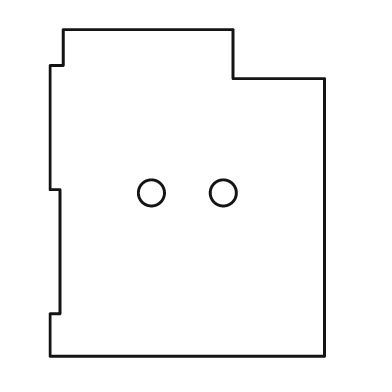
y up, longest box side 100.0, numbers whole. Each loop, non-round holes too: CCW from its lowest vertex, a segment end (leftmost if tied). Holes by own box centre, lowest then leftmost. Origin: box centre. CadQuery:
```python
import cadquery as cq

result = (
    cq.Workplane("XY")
    .moveTo(-42.0, -50.0)
    .lineTo(42.0, -50.0)
    .lineTo(42.0, 35.0)
    .lineTo(14.0, 35.0)
    .lineTo(14.0, 50.0)
    .lineTo(-38.0, 50.0)
    .lineTo(-38.0, 39.0)
    .lineTo(-42.0, 39.0)
    .lineTo(-42.0, 1.0)
    .lineTo(-39.0, 1.0)
    .lineTo(-39.0, -37.0)
    .lineTo(-42.0, -37.0)
    .close()
    .moveTo(-11.0, 0.0)
    .circle(4.0)
    .moveTo(11.0, 0.0)
    .circle(4.0)
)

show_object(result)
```